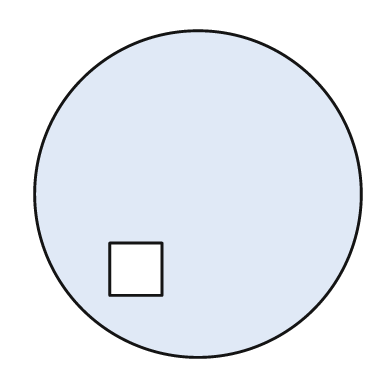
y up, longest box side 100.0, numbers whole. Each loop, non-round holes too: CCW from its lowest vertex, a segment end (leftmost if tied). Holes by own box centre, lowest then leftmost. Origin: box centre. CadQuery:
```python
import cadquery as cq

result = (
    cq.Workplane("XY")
    .moveTo(0.0, 0.0)
    .circle(50.0)
    .moveTo(-27.0, -31.0)
    .lineTo(-11.0, -31.0)
    .lineTo(-11.0, -15.0)
    .lineTo(-27.0, -15.0)
    .close()
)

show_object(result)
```